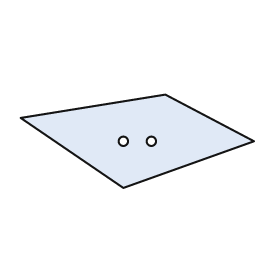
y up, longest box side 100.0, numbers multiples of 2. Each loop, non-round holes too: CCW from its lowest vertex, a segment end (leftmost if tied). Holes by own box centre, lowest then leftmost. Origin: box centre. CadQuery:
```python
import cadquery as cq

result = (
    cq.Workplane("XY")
    .moveTo(-6.0, -20.0)
    .lineTo(50.0, 0.0)
    .lineTo(12.0, 20.0)
    .lineTo(-50.0, 10.0)
    .close()
    .moveTo(-6.0, 0.0)
    .circle(2.0)
    .moveTo(6.0, 0.0)
    .circle(2.0)
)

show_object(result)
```